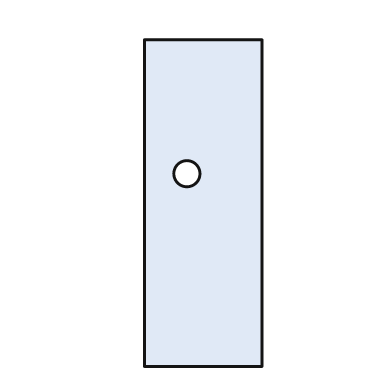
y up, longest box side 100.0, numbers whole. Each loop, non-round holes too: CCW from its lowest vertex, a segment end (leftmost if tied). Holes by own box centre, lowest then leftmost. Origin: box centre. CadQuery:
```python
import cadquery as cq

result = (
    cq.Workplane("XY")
    .moveTo(-18.0, -50.0)
    .lineTo(18.0, -50.0)
    .lineTo(18.0, 50.0)
    .lineTo(-18.0, 50.0)
    .close()
    .moveTo(-5.0, 9.0)
    .circle(4.0)
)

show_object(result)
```